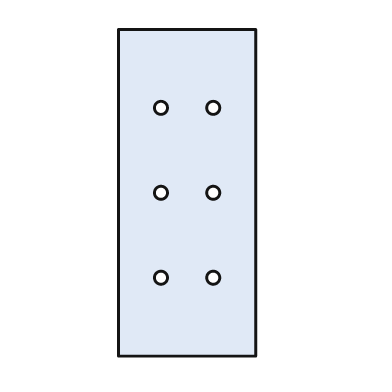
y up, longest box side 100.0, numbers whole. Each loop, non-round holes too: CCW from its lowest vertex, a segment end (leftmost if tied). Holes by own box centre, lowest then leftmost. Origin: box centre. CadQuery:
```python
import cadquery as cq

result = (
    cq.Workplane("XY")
    .moveTo(-21.0, -50.0)
    .lineTo(21.0, -50.0)
    .lineTo(21.0, 50.0)
    .lineTo(-21.0, 50.0)
    .close()
    .moveTo(-8.0, -26.0)
    .circle(2.0)
    .moveTo(8.0, -26.0)
    .circle(2.0)
    .moveTo(-8.0, 0.0)
    .circle(2.0)
    .moveTo(8.0, 0.0)
    .circle(2.0)
    .moveTo(-8.0, 26.0)
    .circle(2.0)
    .moveTo(8.0, 26.0)
    .circle(2.0)
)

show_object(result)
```